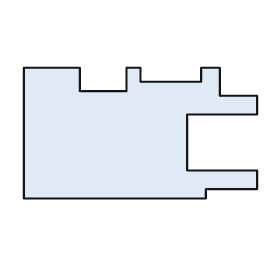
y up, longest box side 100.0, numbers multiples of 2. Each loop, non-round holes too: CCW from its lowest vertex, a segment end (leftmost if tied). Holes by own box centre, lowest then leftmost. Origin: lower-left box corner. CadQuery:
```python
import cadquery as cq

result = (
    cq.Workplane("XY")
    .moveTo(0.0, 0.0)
    .lineTo(78.0, 0.0)
    .lineTo(78.0, 4.0)
    .lineTo(100.0, 4.0)
    .lineTo(100.0, 12.0)
    .lineTo(70.0, 12.0)
    .lineTo(70.0, 36.0)
    .lineTo(100.0, 36.0)
    .lineTo(100.0, 44.0)
    .lineTo(84.0, 44.0)
    .lineTo(84.0, 56.0)
    .lineTo(76.0, 56.0)
    .lineTo(76.0, 50.0)
    .lineTo(50.0, 50.0)
    .lineTo(50.0, 56.0)
    .lineTo(44.0, 56.0)
    .lineTo(44.0, 46.0)
    .lineTo(24.0, 46.0)
    .lineTo(24.0, 56.0)
    .lineTo(0.0, 56.0)
    .close()
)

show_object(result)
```